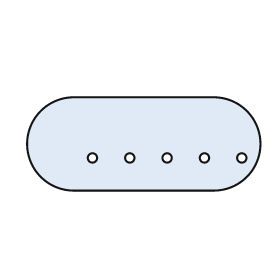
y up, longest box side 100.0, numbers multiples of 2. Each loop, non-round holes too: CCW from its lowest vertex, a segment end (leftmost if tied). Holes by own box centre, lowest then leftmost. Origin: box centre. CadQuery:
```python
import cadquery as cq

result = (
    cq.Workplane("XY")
    .moveTo(-30.0, -20.0)
    .lineTo(30.0, -20.0)
    .threePointArc((50.0, 0.0), (30.0, 20.0))
    .lineTo(-30.0, 20.0)
    .threePointArc((-50.0, 0.0), (-30.0, -20.0))
    .close()
    .moveTo(-22.0, -6.0)
    .circle(2.0)
    .moveTo(-6.0, -6.0)
    .circle(2.0)
    .moveTo(10.0, -6.0)
    .circle(2.0)
    .moveTo(26.0, -6.0)
    .circle(2.0)
    .moveTo(42.0, -6.0)
    .circle(2.0)
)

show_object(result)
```